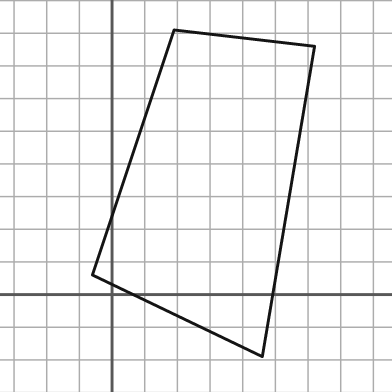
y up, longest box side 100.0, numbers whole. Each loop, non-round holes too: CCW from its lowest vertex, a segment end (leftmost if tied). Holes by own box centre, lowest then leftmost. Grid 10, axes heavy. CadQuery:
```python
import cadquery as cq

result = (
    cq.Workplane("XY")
    .moveTo(46.0, -19.0)
    .lineTo(62.0, 76.0)
    .lineTo(19.0, 81.0)
    .lineTo(-6.0, 6.0)
    .close()
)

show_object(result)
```